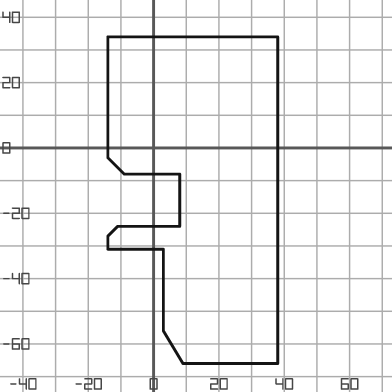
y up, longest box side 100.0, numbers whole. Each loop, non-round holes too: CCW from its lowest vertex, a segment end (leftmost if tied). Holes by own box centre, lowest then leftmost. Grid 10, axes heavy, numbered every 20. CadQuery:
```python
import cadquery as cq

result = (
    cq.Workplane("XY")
    .moveTo(9.0, -66.0)
    .lineTo(38.0, -66.0)
    .lineTo(38.0, 34.0)
    .lineTo(-14.0, 34.0)
    .lineTo(-14.0, -3.0)
    .lineTo(-9.0, -8.0)
    .lineTo(8.0, -8.0)
    .lineTo(8.0, -24.0)
    .lineTo(-11.0, -24.0)
    .lineTo(-14.0, -27.0)
    .lineTo(-14.0, -31.0)
    .lineTo(3.0, -31.0)
    .lineTo(3.0, -56.0)
    .close()
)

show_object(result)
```